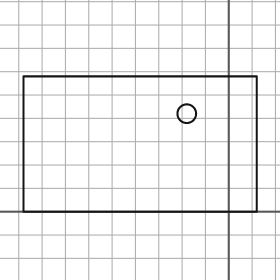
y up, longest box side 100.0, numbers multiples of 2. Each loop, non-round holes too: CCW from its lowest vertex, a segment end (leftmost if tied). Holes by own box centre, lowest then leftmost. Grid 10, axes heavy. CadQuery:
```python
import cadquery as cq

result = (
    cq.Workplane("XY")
    .moveTo(-88.0, 0.0)
    .lineTo(12.0, 0.0)
    .lineTo(12.0, 58.0)
    .lineTo(-88.0, 58.0)
    .close()
    .moveTo(-18.0, 42.0)
    .circle(4.0)
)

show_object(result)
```